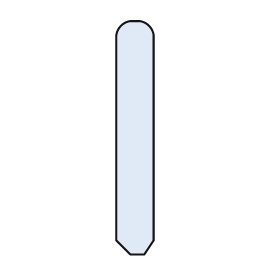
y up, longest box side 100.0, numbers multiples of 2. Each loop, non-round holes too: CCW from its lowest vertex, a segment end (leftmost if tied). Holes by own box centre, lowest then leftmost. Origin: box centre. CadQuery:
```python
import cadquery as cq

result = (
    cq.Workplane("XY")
    .moveTo(-2.0, -50.0)
    .lineTo(4.0, -50.0)
    .lineTo(8.0, -44.0)
    .lineTo(8.0, 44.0)
    .threePointArc((6.0, 48.0), (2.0, 50.0))
    .lineTo(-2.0, 50.0)
    .threePointArc((-6.0, 48.0), (-8.0, 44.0))
    .lineTo(-8.0, -44.0)
    .close()
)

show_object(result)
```